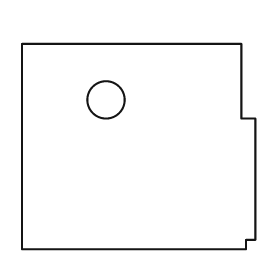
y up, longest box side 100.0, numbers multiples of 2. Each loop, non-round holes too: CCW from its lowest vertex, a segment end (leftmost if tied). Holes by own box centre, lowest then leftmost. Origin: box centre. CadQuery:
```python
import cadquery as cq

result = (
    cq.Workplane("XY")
    .moveTo(-50.0, -44.0)
    .lineTo(46.0, -44.0)
    .lineTo(46.0, -40.0)
    .lineTo(50.0, -40.0)
    .lineTo(50.0, 12.0)
    .lineTo(44.0, 12.0)
    .lineTo(44.0, 44.0)
    .lineTo(-50.0, 44.0)
    .close()
    .moveTo(-14.0, 20.0)
    .circle(8.0)
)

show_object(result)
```